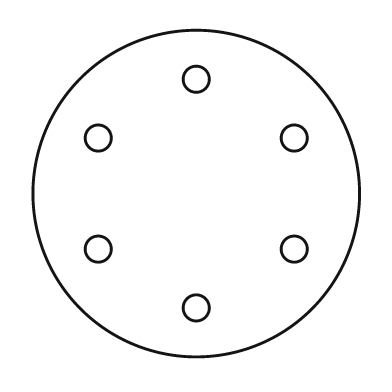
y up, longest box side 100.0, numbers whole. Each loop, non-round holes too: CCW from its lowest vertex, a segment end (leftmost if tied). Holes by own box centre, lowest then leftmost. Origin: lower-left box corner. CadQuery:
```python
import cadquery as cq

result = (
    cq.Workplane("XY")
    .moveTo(50.0, 50.0)
    .circle(50.0)
    .moveTo(50.0, 15.0)
    .circle(4.0)
    .moveTo(20.0, 33.0)
    .circle(4.0)
    .moveTo(80.0, 33.0)
    .circle(4.0)
    .moveTo(20.0, 67.0)
    .circle(4.0)
    .moveTo(80.0, 67.0)
    .circle(4.0)
    .moveTo(50.0, 85.0)
    .circle(4.0)
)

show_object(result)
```